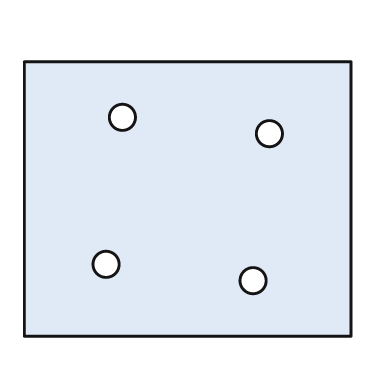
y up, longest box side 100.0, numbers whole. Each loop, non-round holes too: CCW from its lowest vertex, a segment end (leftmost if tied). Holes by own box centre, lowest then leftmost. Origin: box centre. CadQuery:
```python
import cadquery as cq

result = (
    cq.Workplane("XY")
    .moveTo(-50.0, -42.0)
    .lineTo(50.0, -42.0)
    .lineTo(50.0, 42.0)
    .lineTo(-50.0, 42.0)
    .close()
    .moveTo(20.0, -25.0)
    .circle(4.0)
    .moveTo(-25.0, -20.0)
    .circle(4.0)
    .moveTo(25.0, 20.0)
    .circle(4.0)
    .moveTo(-20.0, 25.0)
    .circle(4.0)
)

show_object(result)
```